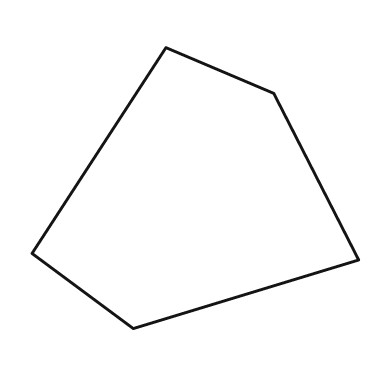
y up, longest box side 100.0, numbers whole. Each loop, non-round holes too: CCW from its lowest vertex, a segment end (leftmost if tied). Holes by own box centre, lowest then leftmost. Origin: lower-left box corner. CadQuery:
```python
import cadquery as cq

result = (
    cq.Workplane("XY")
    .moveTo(31.0, 0.0)
    .lineTo(100.0, 21.0)
    .lineTo(74.0, 72.0)
    .lineTo(41.0, 86.0)
    .lineTo(0.0, 23.0)
    .close()
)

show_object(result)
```